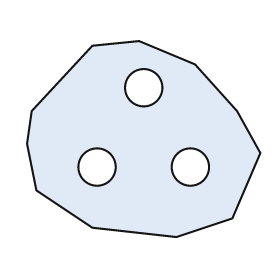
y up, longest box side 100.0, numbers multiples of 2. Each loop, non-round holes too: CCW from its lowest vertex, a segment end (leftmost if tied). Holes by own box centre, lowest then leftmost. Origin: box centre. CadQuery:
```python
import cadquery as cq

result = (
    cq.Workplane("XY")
    .moveTo(14.0, -42.0)
    .lineTo(38.0, -34.0)
    .lineTo(50.0, -6.0)
    .lineTo(40.0, 12.0)
    .lineTo(22.0, 32.0)
    .lineTo(-2.0, 42.0)
    .lineTo(-22.0, 40.0)
    .lineTo(-48.0, 12.0)
    .lineTo(-50.0, -2.0)
    .lineTo(-46.0, -22.0)
    .lineTo(-22.0, -38.0)
    .close()
    .moveTo(-20.0, -12.0)
    .circle(8.0)
    .moveTo(20.0, -12.0)
    .circle(8.0)
    .moveTo(0.0, 22.0)
    .circle(8.0)
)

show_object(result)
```